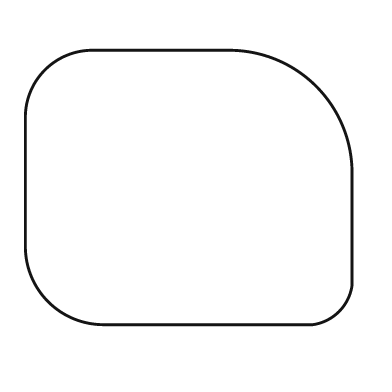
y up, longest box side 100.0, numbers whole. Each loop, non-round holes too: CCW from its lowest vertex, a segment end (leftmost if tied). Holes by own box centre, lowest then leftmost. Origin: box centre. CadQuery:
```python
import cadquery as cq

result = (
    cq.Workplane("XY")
    .moveTo(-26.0, -42.0)
    .lineTo(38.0, -42.0)
    .threePointArc((46.0, -38.0), (50.0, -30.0))
    .lineTo(50.0, 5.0)
    .threePointArc((39.0, 31.0), (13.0, 42.0))
    .lineTo(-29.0, 42.0)
    .threePointArc((-44.0, 36.0), (-50.0, 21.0))
    .lineTo(-50.0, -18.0)
    .threePointArc((-43.0, -35.0), (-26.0, -42.0))
    .close()
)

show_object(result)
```